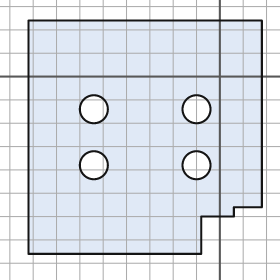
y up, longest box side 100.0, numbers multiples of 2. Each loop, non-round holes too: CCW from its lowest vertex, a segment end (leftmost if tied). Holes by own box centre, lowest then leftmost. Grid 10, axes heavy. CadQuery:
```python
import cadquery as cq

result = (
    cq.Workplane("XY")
    .moveTo(-82.0, -76.0)
    .lineTo(-8.0, -76.0)
    .lineTo(-8.0, -60.0)
    .lineTo(6.0, -60.0)
    .lineTo(6.0, -56.0)
    .lineTo(18.0, -56.0)
    .lineTo(18.0, 24.0)
    .lineTo(-82.0, 24.0)
    .close()
    .moveTo(-54.0, -38.0)
    .circle(6.0)
    .moveTo(-10.0, -38.0)
    .circle(6.0)
    .moveTo(-54.0, -14.0)
    .circle(6.0)
    .moveTo(-10.0, -14.0)
    .circle(6.0)
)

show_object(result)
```